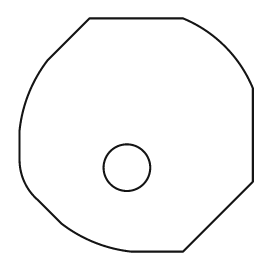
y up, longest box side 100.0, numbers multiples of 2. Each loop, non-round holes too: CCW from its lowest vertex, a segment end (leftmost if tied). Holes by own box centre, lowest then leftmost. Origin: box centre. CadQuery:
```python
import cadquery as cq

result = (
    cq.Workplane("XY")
    .moveTo(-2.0, -50.0)
    .lineTo(20.0, -50.0)
    .lineTo(50.0, -20.0)
    .lineTo(50.0, 20.0)
    .threePointArc((38.0, 38.0), (20.0, 50.0))
    .lineTo(-20.0, 50.0)
    .lineTo(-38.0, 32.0)
    .threePointArc((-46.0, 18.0), (-50.0, 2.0))
    .lineTo(-50.0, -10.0)
    .threePointArc((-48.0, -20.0), (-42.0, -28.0))
    .lineTo(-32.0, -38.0)
    .threePointArc((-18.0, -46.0), (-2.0, -50.0))
    .close()
    .moveTo(-4.0, -14.0)
    .circle(10.0)
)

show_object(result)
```